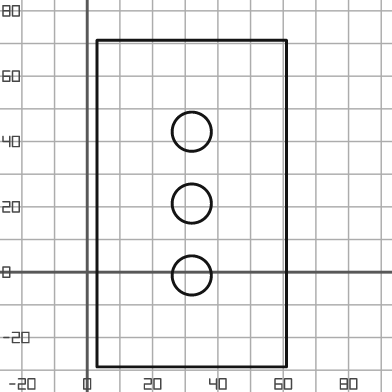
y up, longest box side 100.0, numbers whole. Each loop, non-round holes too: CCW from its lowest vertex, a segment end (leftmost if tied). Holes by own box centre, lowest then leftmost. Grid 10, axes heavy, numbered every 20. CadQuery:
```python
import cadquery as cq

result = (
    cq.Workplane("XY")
    .moveTo(3.0, -29.0)
    .lineTo(61.0, -29.0)
    .lineTo(61.0, 71.0)
    .lineTo(3.0, 71.0)
    .close()
    .moveTo(32.0, -1.0)
    .circle(6.0)
    .moveTo(32.0, 21.0)
    .circle(6.0)
    .moveTo(32.0, 43.0)
    .circle(6.0)
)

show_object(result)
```